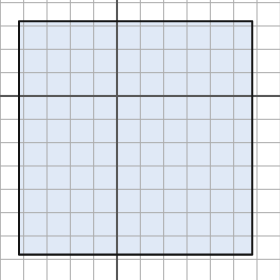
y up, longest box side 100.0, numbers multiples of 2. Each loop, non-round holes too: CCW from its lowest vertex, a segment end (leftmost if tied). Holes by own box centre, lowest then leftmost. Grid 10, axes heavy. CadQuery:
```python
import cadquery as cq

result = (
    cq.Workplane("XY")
    .moveTo(-42.0, -68.0)
    .lineTo(58.0, -68.0)
    .lineTo(58.0, 32.0)
    .lineTo(-42.0, 32.0)
    .close()
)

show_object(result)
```